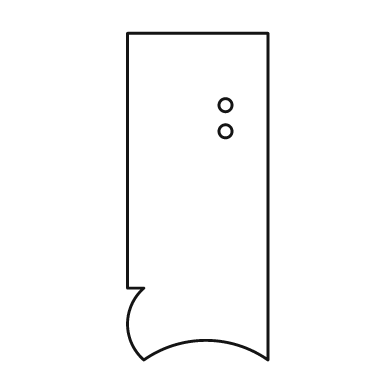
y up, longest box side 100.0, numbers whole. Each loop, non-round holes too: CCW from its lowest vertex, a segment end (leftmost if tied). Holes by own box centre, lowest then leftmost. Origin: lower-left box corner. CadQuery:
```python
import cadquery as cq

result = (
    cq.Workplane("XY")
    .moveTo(5.0, 0.0)
    .threePointArc((24.0, 6.0), (43.0, 0.0))
    .lineTo(43.0, 100.0)
    .lineTo(0.0, 100.0)
    .lineTo(0.0, 22.0)
    .lineTo(5.0, 22.0)
    .threePointArc((0.0, 11.0), (5.0, 0.0))
    .close()
    .moveTo(30.0, 70.0)
    .circle(2.0)
    .moveTo(30.0, 78.0)
    .circle(2.0)
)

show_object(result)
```